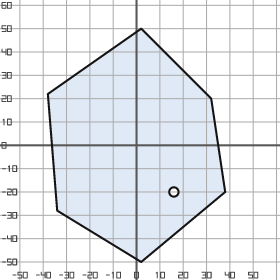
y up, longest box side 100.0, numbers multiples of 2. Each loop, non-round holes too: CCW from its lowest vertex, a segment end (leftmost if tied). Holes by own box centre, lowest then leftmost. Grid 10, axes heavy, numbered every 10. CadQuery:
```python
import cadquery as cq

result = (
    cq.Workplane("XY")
    .moveTo(2.0, -50.0)
    .lineTo(38.0, -20.0)
    .lineTo(32.0, 20.0)
    .lineTo(2.0, 50.0)
    .lineTo(-38.0, 22.0)
    .lineTo(-34.0, -28.0)
    .close()
    .moveTo(16.0, -20.0)
    .circle(2.0)
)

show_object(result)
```